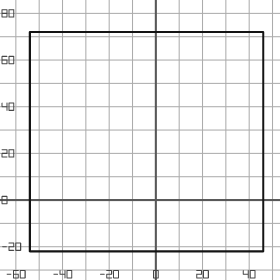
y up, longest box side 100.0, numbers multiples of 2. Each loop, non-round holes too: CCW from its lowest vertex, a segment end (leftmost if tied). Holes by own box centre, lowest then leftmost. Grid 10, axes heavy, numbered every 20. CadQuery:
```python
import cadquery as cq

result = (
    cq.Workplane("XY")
    .moveTo(-54.0, -22.0)
    .lineTo(46.0, -22.0)
    .lineTo(46.0, 72.0)
    .lineTo(-54.0, 72.0)
    .close()
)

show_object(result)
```